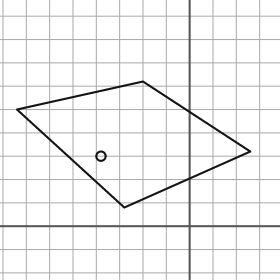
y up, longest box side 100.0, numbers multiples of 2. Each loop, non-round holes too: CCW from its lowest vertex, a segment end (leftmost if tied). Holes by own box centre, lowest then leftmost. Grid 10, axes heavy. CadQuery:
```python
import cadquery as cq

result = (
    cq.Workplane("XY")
    .moveTo(-28.0, 8.0)
    .lineTo(26.0, 32.0)
    .lineTo(-20.0, 62.0)
    .lineTo(-74.0, 50.0)
    .close()
    .moveTo(-38.0, 30.0)
    .circle(2.0)
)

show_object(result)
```